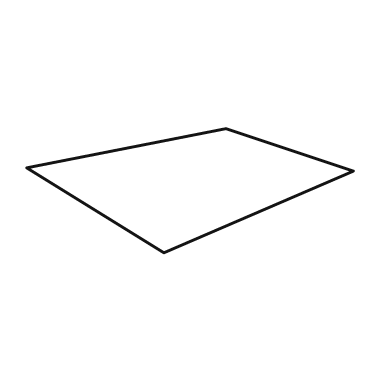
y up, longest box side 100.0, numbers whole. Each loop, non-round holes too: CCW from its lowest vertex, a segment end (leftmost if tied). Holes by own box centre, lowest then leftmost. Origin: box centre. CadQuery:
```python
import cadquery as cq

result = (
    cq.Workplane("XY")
    .moveTo(-8.0, -19.0)
    .lineTo(50.0, 6.0)
    .lineTo(11.0, 19.0)
    .lineTo(-50.0, 7.0)
    .close()
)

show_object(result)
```